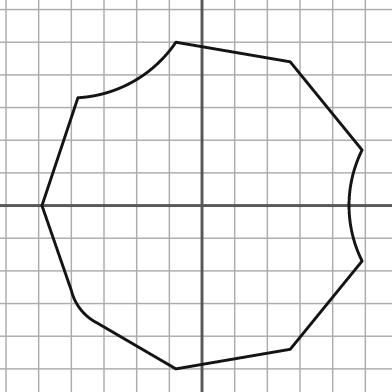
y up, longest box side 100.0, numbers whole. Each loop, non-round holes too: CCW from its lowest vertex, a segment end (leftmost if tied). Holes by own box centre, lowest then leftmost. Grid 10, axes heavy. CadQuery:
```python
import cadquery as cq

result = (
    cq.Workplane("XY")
    .moveTo(-8.0, -50.0)
    .lineTo(27.0, -44.0)
    .lineTo(49.0, -17.0)
    .threePointArc((45.0, 0.0), (49.0, 17.0))
    .lineTo(27.0, 44.0)
    .lineTo(-8.0, 50.0)
    .threePointArc((-21.0, 38.0), (-38.0, 33.0))
    .lineTo(-49.0, 0.0)
    .lineTo(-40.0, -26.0)
    .threePointArc((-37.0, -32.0), (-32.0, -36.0))
    .close()
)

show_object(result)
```